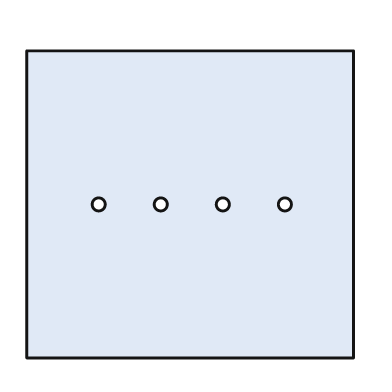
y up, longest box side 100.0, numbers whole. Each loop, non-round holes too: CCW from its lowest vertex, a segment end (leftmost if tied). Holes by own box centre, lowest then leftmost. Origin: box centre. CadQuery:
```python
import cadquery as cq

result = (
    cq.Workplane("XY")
    .moveTo(-50.0, -47.0)
    .lineTo(50.0, -47.0)
    .lineTo(50.0, 47.0)
    .lineTo(-50.0, 47.0)
    .close()
    .moveTo(-28.0, 0.0)
    .circle(2.0)
    .moveTo(-9.0, 0.0)
    .circle(2.0)
    .moveTo(10.0, 0.0)
    .circle(2.0)
    .moveTo(29.0, 0.0)
    .circle(2.0)
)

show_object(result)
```